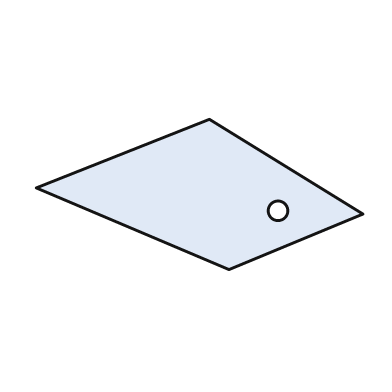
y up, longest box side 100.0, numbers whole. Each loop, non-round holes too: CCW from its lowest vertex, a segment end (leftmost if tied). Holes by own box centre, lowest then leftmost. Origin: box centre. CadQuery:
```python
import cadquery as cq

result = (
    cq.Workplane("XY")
    .moveTo(9.0, -23.0)
    .lineTo(50.0, -6.0)
    .lineTo(3.0, 23.0)
    .lineTo(-50.0, 2.0)
    .close()
    .moveTo(24.0, -5.0)
    .circle(3.0)
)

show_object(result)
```